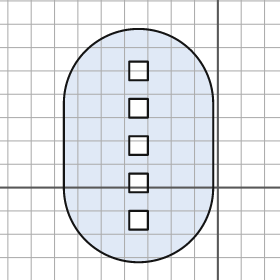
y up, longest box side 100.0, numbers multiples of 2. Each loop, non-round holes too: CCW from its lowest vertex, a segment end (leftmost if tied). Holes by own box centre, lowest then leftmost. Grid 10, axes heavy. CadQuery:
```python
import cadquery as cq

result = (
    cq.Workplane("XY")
    .moveTo(-66.0, 0.0)
    .threePointArc((-34.0, -32.0), (-2.0, 0.0))
    .lineTo(-2.0, 36.0)
    .threePointArc((-34.0, 68.0), (-66.0, 36.0))
    .close()
    .moveTo(-38.0, -18.0)
    .lineTo(-30.0, -18.0)
    .lineTo(-30.0, -10.0)
    .lineTo(-38.0, -10.0)
    .close()
    .moveTo(-38.0, -2.0)
    .lineTo(-30.0, -2.0)
    .lineTo(-30.0, 6.0)
    .lineTo(-38.0, 6.0)
    .close()
    .moveTo(-38.0, 14.0)
    .lineTo(-30.0, 14.0)
    .lineTo(-30.0, 22.0)
    .lineTo(-38.0, 22.0)
    .close()
    .moveTo(-38.0, 30.0)
    .lineTo(-30.0, 30.0)
    .lineTo(-30.0, 38.0)
    .lineTo(-38.0, 38.0)
    .close()
    .moveTo(-38.0, 46.0)
    .lineTo(-30.0, 46.0)
    .lineTo(-30.0, 54.0)
    .lineTo(-38.0, 54.0)
    .close()
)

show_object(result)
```